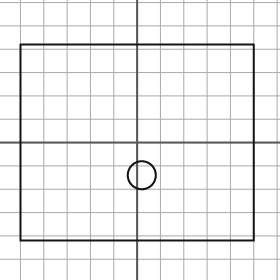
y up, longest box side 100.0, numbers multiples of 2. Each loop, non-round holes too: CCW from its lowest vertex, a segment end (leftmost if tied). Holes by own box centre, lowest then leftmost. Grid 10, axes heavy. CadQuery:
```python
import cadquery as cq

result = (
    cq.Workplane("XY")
    .moveTo(-50.0, -42.0)
    .lineTo(50.0, -42.0)
    .lineTo(50.0, 42.0)
    .lineTo(-50.0, 42.0)
    .close()
    .moveTo(2.0, -14.0)
    .circle(6.0)
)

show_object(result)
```